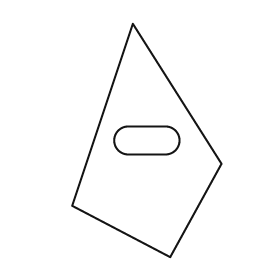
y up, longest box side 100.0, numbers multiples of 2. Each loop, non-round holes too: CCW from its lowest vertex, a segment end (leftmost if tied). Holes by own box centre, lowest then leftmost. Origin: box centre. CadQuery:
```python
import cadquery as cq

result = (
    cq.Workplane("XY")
    .moveTo(10.0, -50.0)
    .lineTo(32.0, -10.0)
    .lineTo(-6.0, 50.0)
    .lineTo(-32.0, -28.0)
    .close()
    .moveTo(-8.0, -6.0)
    .lineTo(8.0, -6.0)
    .threePointArc((14.0, 0.0), (8.0, 6.0))
    .lineTo(-8.0, 6.0)
    .threePointArc((-14.0, 0.0), (-8.0, -6.0))
    .close()
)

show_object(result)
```